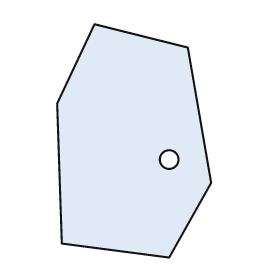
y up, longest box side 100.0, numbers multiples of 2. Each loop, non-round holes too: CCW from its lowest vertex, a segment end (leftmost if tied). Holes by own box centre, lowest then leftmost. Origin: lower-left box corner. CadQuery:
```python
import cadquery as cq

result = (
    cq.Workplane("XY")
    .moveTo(48.0, 0.0)
    .lineTo(66.0, 32.0)
    .lineTo(56.0, 90.0)
    .lineTo(16.0, 100.0)
    .lineTo(0.0, 66.0)
    .lineTo(2.0, 6.0)
    .close()
    .moveTo(48.0, 42.0)
    .circle(4.0)
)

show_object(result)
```